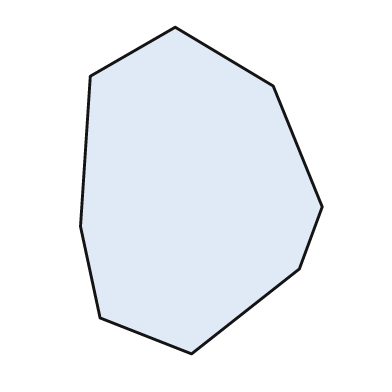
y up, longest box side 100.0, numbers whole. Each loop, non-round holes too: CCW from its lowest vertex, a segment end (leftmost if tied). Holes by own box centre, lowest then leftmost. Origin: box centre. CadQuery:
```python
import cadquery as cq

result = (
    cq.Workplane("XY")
    .moveTo(-3.0, -50.0)
    .lineTo(30.0, -24.0)
    .lineTo(37.0, -5.0)
    .lineTo(22.0, 32.0)
    .lineTo(-8.0, 50.0)
    .lineTo(-34.0, 35.0)
    .lineTo(-37.0, -11.0)
    .lineTo(-31.0, -39.0)
    .close()
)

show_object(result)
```